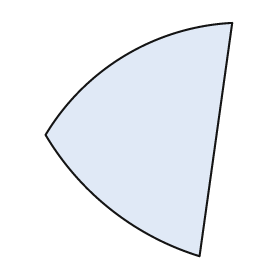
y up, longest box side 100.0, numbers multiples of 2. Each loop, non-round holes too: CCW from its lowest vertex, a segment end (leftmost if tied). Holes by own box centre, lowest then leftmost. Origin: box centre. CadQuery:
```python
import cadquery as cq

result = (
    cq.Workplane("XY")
    .moveTo(26.0, -50.0)
    .lineTo(40.0, 50.0)
    .threePointArc((-6.0, 36.0), (-40.0, 2.0))
    .threePointArc((-12.0, -30.0), (26.0, -50.0))
    .close()
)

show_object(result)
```